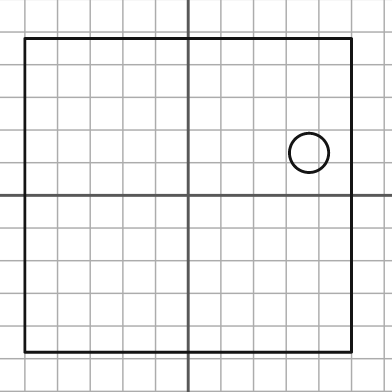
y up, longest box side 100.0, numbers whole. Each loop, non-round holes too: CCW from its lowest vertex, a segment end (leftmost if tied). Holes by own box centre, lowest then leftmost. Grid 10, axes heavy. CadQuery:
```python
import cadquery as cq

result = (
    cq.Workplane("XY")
    .moveTo(-50.0, -48.0)
    .lineTo(50.0, -48.0)
    .lineTo(50.0, 48.0)
    .lineTo(-50.0, 48.0)
    .close()
    .moveTo(37.0, 13.0)
    .circle(6.0)
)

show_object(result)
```